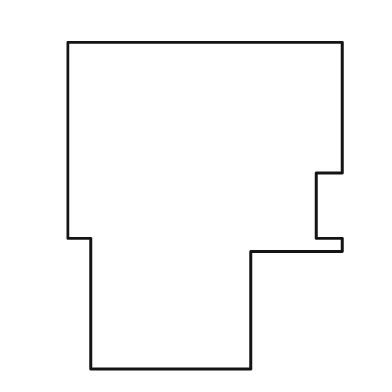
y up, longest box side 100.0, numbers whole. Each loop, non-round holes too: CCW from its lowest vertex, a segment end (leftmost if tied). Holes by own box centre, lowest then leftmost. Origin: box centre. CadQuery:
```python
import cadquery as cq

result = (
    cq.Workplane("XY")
    .moveTo(-35.0, -50.0)
    .lineTo(14.0, -50.0)
    .lineTo(14.0, -14.0)
    .lineTo(42.0, -14.0)
    .lineTo(42.0, -10.0)
    .lineTo(34.0, -10.0)
    .lineTo(34.0, 10.0)
    .lineTo(42.0, 10.0)
    .lineTo(42.0, 50.0)
    .lineTo(-42.0, 50.0)
    .lineTo(-42.0, -10.0)
    .lineTo(-35.0, -10.0)
    .close()
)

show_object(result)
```